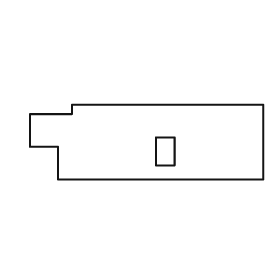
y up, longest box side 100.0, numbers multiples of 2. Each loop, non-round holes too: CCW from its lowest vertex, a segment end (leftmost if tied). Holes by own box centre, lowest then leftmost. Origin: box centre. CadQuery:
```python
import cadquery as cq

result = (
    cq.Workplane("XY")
    .moveTo(-38.0, -16.0)
    .lineTo(50.0, -16.0)
    .lineTo(50.0, 16.0)
    .lineTo(-32.0, 16.0)
    .lineTo(-32.0, 12.0)
    .lineTo(-50.0, 12.0)
    .lineTo(-50.0, -2.0)
    .lineTo(-38.0, -2.0)
    .close()
    .moveTo(4.0, -10.0)
    .lineTo(12.0, -10.0)
    .lineTo(12.0, 2.0)
    .lineTo(4.0, 2.0)
    .close()
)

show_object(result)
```